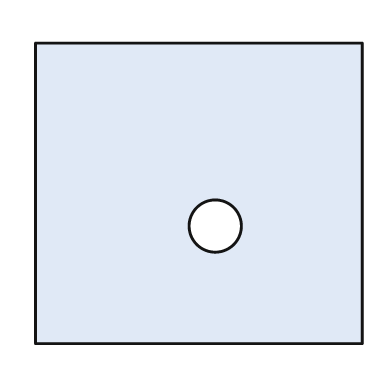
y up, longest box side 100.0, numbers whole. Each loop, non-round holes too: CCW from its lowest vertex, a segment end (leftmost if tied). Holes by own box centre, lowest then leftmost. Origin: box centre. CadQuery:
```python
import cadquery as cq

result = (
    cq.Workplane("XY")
    .moveTo(-50.0, -46.0)
    .lineTo(50.0, -46.0)
    .lineTo(50.0, 46.0)
    .lineTo(-50.0, 46.0)
    .close()
    .moveTo(5.0, -10.0)
    .circle(8.0)
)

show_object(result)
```